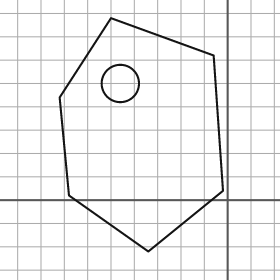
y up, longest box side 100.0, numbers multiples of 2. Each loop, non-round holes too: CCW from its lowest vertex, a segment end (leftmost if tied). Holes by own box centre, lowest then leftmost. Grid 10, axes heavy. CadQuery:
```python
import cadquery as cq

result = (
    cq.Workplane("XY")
    .moveTo(-34.0, -22.0)
    .lineTo(-2.0, 4.0)
    .lineTo(-6.0, 62.0)
    .lineTo(-50.0, 78.0)
    .lineTo(-72.0, 44.0)
    .lineTo(-68.0, 2.0)
    .close()
    .moveTo(-46.0, 50.0)
    .circle(8.0)
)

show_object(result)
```